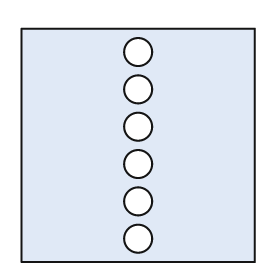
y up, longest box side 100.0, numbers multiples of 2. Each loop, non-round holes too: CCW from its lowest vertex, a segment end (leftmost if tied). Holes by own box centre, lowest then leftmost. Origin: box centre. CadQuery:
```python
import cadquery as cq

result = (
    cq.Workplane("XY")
    .moveTo(-50.0, -50.0)
    .lineTo(50.0, -50.0)
    .lineTo(50.0, 50.0)
    .lineTo(-50.0, 50.0)
    .close()
    .moveTo(0.0, -40.0)
    .circle(6.0)
    .moveTo(0.0, -24.0)
    .circle(6.0)
    .moveTo(0.0, -8.0)
    .circle(6.0)
    .moveTo(0.0, 8.0)
    .circle(6.0)
    .moveTo(0.0, 24.0)
    .circle(6.0)
    .moveTo(0.0, 40.0)
    .circle(6.0)
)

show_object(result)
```